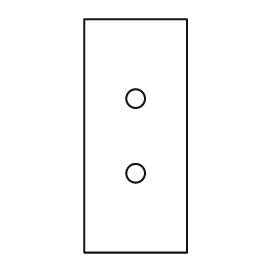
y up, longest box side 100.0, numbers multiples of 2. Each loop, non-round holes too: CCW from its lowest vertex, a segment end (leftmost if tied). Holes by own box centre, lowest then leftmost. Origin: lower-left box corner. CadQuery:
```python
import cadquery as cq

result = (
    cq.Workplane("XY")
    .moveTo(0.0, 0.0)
    .lineTo(44.0, 0.0)
    .lineTo(44.0, 100.0)
    .lineTo(0.0, 100.0)
    .close()
    .moveTo(22.0, 34.0)
    .circle(4.0)
    .moveTo(22.0, 66.0)
    .circle(4.0)
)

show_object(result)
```